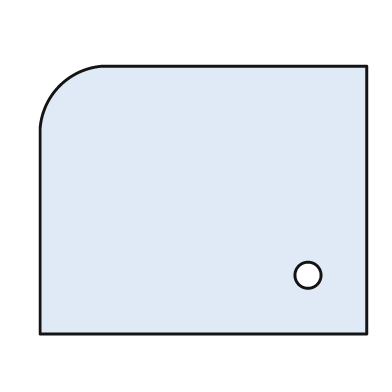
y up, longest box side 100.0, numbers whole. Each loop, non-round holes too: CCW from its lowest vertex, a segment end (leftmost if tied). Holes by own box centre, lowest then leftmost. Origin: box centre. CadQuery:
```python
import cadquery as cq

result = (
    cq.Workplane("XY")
    .moveTo(-50.0, -41.0)
    .lineTo(50.0, -41.0)
    .lineTo(50.0, 41.0)
    .lineTo(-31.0, 41.0)
    .threePointArc((-44.0, 35.0), (-50.0, 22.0))
    .close()
    .moveTo(32.0, -23.0)
    .circle(4.0)
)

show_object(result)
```